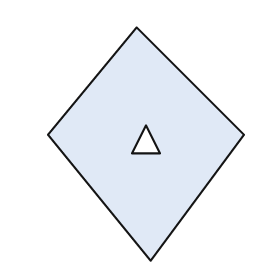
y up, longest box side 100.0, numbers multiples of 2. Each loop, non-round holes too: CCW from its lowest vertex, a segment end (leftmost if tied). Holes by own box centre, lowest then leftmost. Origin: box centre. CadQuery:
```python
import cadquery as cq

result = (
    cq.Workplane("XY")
    .moveTo(2.0, -50.0)
    .lineTo(42.0, 4.0)
    .lineTo(-4.0, 50.0)
    .lineTo(-42.0, 4.0)
    .close()
    .moveTo(-6.0, -4.0)
    .lineTo(6.0, -4.0)
    .lineTo(0.0, 8.0)
    .close()
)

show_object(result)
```